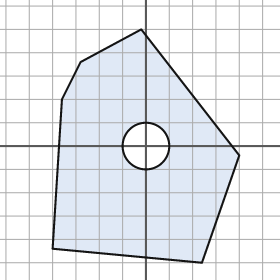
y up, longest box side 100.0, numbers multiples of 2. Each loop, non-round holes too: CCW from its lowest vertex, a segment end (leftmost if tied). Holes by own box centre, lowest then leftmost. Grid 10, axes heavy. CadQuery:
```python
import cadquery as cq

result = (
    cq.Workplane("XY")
    .moveTo(24.0, -50.0)
    .lineTo(40.0, -4.0)
    .lineTo(-2.0, 50.0)
    .lineTo(-28.0, 36.0)
    .lineTo(-36.0, 20.0)
    .lineTo(-40.0, -44.0)
    .close()
    .moveTo(0.0, 0.0)
    .circle(10.0)
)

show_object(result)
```